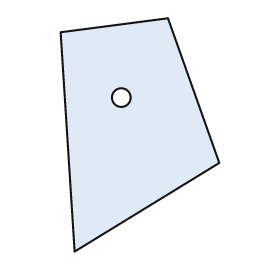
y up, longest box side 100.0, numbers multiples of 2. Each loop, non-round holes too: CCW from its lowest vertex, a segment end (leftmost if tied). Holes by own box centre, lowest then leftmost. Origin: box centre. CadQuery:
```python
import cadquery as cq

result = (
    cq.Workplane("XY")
    .moveTo(-28.0, -50.0)
    .lineTo(34.0, -12.0)
    .lineTo(12.0, 50.0)
    .lineTo(-34.0, 44.0)
    .close()
    .moveTo(-8.0, 16.0)
    .circle(4.0)
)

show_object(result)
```